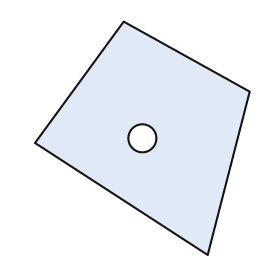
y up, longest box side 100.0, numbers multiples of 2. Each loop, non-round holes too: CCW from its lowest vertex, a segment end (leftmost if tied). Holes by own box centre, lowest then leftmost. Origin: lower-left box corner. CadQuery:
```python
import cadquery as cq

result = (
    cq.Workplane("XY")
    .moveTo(74.0, 0.0)
    .lineTo(92.0, 70.0)
    .lineTo(38.0, 100.0)
    .lineTo(0.0, 48.0)
    .close()
    .moveTo(46.0, 50.0)
    .circle(6.0)
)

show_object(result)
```